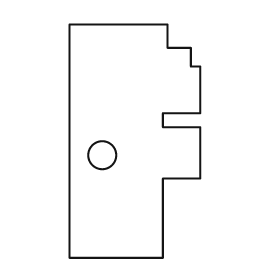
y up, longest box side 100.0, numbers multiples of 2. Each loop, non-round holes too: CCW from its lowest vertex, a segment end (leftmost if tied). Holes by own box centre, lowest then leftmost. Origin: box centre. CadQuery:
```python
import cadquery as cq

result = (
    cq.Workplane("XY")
    .moveTo(-28.0, -50.0)
    .lineTo(12.0, -50.0)
    .lineTo(12.0, -16.0)
    .lineTo(28.0, -16.0)
    .lineTo(28.0, 6.0)
    .lineTo(12.0, 6.0)
    .lineTo(12.0, 12.0)
    .lineTo(28.0, 12.0)
    .lineTo(28.0, 32.0)
    .lineTo(24.0, 32.0)
    .lineTo(24.0, 40.0)
    .lineTo(14.0, 40.0)
    .lineTo(14.0, 50.0)
    .lineTo(-28.0, 50.0)
    .close()
    .moveTo(-14.0, -6.0)
    .circle(6.0)
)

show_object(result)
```